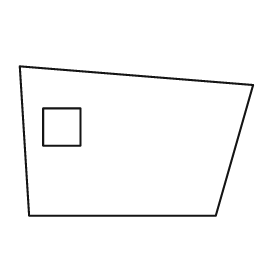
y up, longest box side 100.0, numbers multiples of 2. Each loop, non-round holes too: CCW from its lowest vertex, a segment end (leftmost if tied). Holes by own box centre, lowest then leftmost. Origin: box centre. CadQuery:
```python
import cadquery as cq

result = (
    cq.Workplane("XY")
    .moveTo(-46.0, -32.0)
    .lineTo(34.0, -32.0)
    .lineTo(50.0, 24.0)
    .lineTo(-50.0, 32.0)
    .close()
    .moveTo(-40.0, -2.0)
    .lineTo(-24.0, -2.0)
    .lineTo(-24.0, 14.0)
    .lineTo(-40.0, 14.0)
    .close()
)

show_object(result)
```